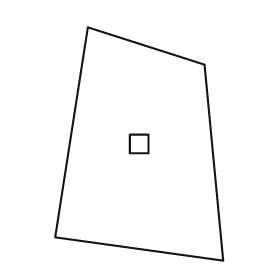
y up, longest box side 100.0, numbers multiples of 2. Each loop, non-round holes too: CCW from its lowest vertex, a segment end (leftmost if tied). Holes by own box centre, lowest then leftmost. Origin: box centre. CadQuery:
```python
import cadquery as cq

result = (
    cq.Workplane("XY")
    .moveTo(36.0, -50.0)
    .lineTo(28.0, 34.0)
    .lineTo(-22.0, 50.0)
    .lineTo(-36.0, -40.0)
    .close()
    .moveTo(-4.0, -4.0)
    .lineTo(4.0, -4.0)
    .lineTo(4.0, 4.0)
    .lineTo(-4.0, 4.0)
    .close()
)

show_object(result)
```